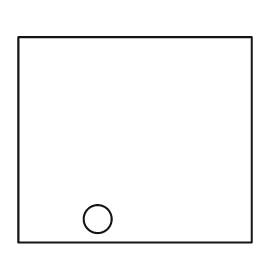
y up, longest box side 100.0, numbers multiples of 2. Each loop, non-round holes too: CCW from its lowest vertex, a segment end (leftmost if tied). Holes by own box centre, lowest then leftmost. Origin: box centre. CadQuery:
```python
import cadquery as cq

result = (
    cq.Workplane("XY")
    .moveTo(-50.0, -44.0)
    .lineTo(50.0, -44.0)
    .lineTo(50.0, 44.0)
    .lineTo(-50.0, 44.0)
    .close()
    .moveTo(-16.0, -34.0)
    .circle(6.0)
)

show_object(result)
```